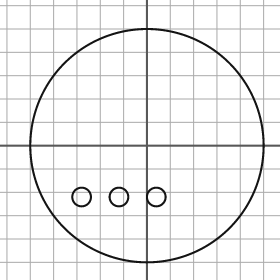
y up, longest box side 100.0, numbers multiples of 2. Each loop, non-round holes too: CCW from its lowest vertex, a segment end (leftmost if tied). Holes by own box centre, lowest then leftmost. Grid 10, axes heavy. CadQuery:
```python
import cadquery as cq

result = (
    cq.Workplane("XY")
    .moveTo(0.0, 0.0)
    .circle(50.0)
    .moveTo(-28.0, -22.0)
    .circle(4.0)
    .moveTo(-12.0, -22.0)
    .circle(4.0)
    .moveTo(4.0, -22.0)
    .circle(4.0)
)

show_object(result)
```